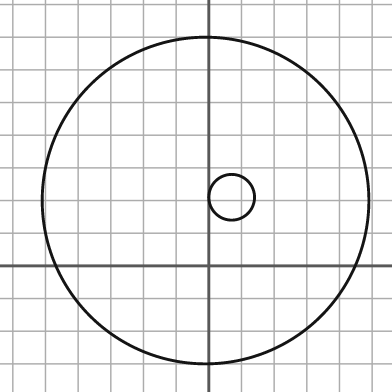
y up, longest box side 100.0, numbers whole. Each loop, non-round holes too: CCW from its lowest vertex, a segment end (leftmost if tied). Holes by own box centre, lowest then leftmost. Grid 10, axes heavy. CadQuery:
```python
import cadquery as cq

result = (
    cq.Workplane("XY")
    .moveTo(-1.0, 20.0)
    .circle(50.0)
    .moveTo(7.0, 21.0)
    .circle(7.0)
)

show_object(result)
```